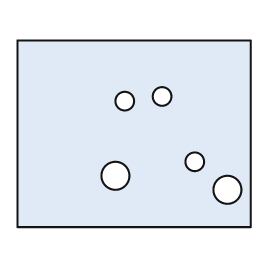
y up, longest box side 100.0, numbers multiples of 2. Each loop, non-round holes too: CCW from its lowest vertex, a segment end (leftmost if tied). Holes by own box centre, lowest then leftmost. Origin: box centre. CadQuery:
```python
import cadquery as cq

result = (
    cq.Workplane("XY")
    .moveTo(-50.0, -40.0)
    .lineTo(50.0, -40.0)
    .lineTo(50.0, 40.0)
    .lineTo(-50.0, 40.0)
    .close()
    .moveTo(40.0, -24.0)
    .circle(6.0)
    .moveTo(-8.0, -18.0)
    .circle(6.0)
    .moveTo(26.0, -12.0)
    .circle(4.0)
    .moveTo(-4.0, 14.0)
    .circle(4.0)
    .moveTo(12.0, 16.0)
    .circle(4.0)
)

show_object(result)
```